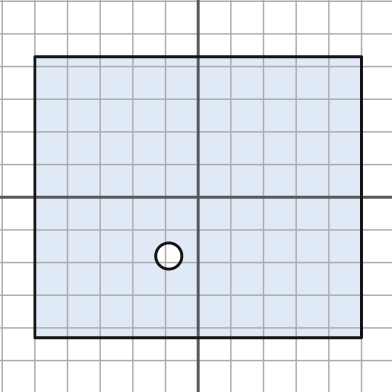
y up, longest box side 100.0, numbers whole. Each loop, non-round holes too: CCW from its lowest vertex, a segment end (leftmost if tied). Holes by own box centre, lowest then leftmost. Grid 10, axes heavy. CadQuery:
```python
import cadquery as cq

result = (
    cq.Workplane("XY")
    .moveTo(-50.0, -43.0)
    .lineTo(50.0, -43.0)
    .lineTo(50.0, 43.0)
    .lineTo(-50.0, 43.0)
    .close()
    .moveTo(-9.0, -18.0)
    .circle(4.0)
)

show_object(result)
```